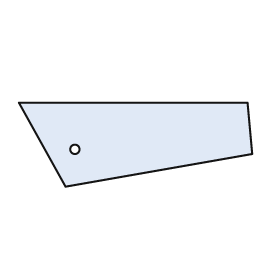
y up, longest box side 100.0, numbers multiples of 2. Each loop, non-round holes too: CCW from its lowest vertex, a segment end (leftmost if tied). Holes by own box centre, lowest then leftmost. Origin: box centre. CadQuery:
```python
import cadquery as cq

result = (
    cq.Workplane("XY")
    .moveTo(-30.0, -18.0)
    .lineTo(50.0, -4.0)
    .lineTo(48.0, 18.0)
    .lineTo(-50.0, 18.0)
    .close()
    .moveTo(-26.0, -2.0)
    .circle(2.0)
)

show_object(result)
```